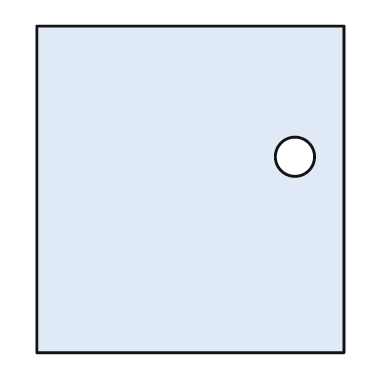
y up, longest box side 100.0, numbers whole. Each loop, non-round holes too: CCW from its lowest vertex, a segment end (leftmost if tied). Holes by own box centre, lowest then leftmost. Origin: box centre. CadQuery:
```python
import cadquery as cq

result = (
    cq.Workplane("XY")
    .moveTo(-47.0, -50.0)
    .lineTo(47.0, -50.0)
    .lineTo(47.0, 50.0)
    .lineTo(-47.0, 50.0)
    .close()
    .moveTo(32.0, 10.0)
    .circle(6.0)
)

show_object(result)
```